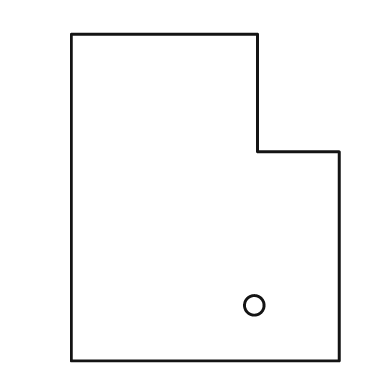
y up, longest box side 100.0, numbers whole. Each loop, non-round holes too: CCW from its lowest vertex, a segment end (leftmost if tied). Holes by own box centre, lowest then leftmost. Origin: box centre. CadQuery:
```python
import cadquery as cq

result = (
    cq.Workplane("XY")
    .moveTo(-41.0, -50.0)
    .lineTo(41.0, -50.0)
    .lineTo(41.0, 14.0)
    .lineTo(16.0, 14.0)
    .lineTo(16.0, 50.0)
    .lineTo(-41.0, 50.0)
    .close()
    .moveTo(15.0, -33.0)
    .circle(3.0)
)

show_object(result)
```